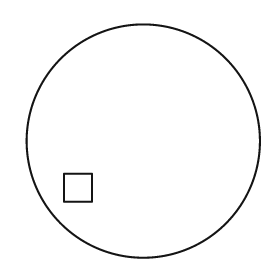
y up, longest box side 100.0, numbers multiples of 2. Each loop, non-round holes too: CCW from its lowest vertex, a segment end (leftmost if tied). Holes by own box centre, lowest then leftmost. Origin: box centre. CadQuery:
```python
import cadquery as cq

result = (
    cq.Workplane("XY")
    .moveTo(0.0, 0.0)
    .circle(50.0)
    .moveTo(-34.0, -26.0)
    .lineTo(-22.0, -26.0)
    .lineTo(-22.0, -14.0)
    .lineTo(-34.0, -14.0)
    .close()
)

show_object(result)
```